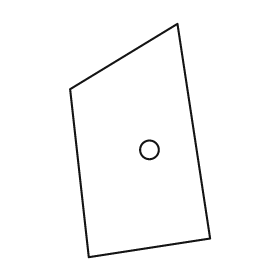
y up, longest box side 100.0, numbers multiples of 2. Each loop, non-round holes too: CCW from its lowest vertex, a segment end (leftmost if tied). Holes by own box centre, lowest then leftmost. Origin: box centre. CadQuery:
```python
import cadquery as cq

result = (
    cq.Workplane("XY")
    .moveTo(-22.0, -50.0)
    .lineTo(30.0, -42.0)
    .lineTo(16.0, 50.0)
    .lineTo(-30.0, 22.0)
    .close()
    .moveTo(4.0, -4.0)
    .circle(4.0)
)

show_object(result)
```